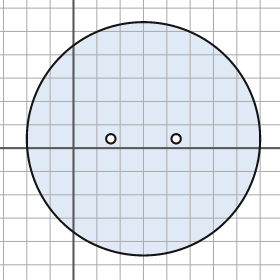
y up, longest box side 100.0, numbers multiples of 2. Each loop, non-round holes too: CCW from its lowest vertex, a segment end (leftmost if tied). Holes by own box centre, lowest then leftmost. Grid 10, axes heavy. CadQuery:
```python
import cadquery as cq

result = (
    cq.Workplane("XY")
    .moveTo(30.0, 4.0)
    .circle(50.0)
    .moveTo(16.0, 4.0)
    .circle(2.0)
    .moveTo(44.0, 4.0)
    .circle(2.0)
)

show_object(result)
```